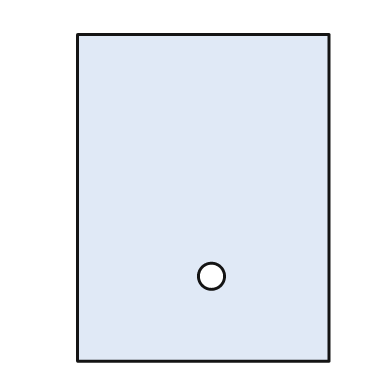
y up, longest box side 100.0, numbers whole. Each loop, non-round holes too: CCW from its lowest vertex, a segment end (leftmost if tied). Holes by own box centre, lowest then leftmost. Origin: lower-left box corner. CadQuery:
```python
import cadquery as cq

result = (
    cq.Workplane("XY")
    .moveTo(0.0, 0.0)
    .lineTo(77.0, 0.0)
    .lineTo(77.0, 100.0)
    .lineTo(0.0, 100.0)
    .close()
    .moveTo(41.0, 26.0)
    .circle(4.0)
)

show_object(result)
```